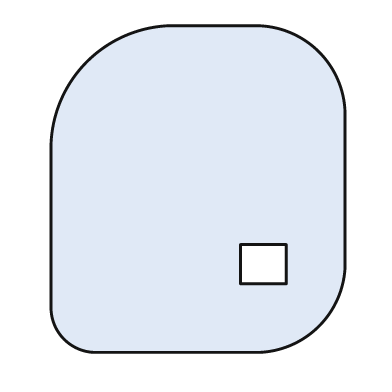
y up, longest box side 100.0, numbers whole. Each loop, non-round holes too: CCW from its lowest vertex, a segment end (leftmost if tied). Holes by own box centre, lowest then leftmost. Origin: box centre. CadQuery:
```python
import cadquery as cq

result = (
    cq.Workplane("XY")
    .moveTo(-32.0, -50.0)
    .lineTo(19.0, -50.0)
    .threePointArc((37.0, -42.0), (45.0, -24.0))
    .lineTo(45.0, 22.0)
    .threePointArc((37.0, 42.0), (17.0, 50.0))
    .lineTo(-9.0, 50.0)
    .threePointArc((-34.0, 39.0), (-45.0, 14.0))
    .lineTo(-45.0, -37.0)
    .threePointArc((-41.0, -46.0), (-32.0, -50.0))
    .close()
    .moveTo(13.0, -29.0)
    .lineTo(27.0, -29.0)
    .lineTo(27.0, -17.0)
    .lineTo(13.0, -17.0)
    .close()
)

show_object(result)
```